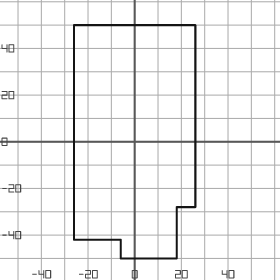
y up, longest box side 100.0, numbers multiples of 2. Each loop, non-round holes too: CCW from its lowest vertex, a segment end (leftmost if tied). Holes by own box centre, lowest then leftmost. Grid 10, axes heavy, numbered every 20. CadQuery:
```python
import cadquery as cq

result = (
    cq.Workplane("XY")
    .moveTo(-6.0, -50.0)
    .lineTo(18.0, -50.0)
    .lineTo(18.0, -28.0)
    .lineTo(26.0, -28.0)
    .lineTo(26.0, 50.0)
    .lineTo(-26.0, 50.0)
    .lineTo(-26.0, -42.0)
    .lineTo(-6.0, -42.0)
    .close()
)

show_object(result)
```